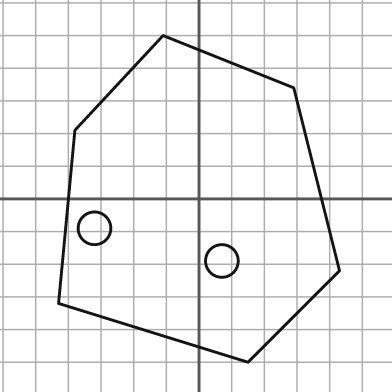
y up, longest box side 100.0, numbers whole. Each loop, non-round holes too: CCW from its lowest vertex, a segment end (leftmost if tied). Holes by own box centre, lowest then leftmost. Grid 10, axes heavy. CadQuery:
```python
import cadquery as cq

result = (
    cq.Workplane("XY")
    .moveTo(15.0, -50.0)
    .lineTo(43.0, -22.0)
    .lineTo(29.0, 34.0)
    .lineTo(-11.0, 50.0)
    .lineTo(-38.0, 21.0)
    .lineTo(-43.0, -32.0)
    .close()
    .moveTo(7.0, -19.0)
    .circle(5.0)
    .moveTo(-32.0, -9.0)
    .circle(5.0)
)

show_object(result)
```